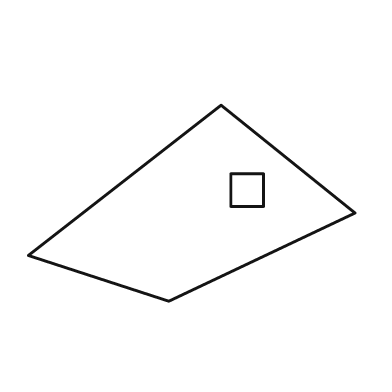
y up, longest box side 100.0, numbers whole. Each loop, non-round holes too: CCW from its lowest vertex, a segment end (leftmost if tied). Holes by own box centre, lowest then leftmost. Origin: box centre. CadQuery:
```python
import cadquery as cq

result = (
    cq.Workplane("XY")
    .moveTo(-7.0, -30.0)
    .lineTo(50.0, -3.0)
    .lineTo(9.0, 30.0)
    .lineTo(-50.0, -16.0)
    .close()
    .moveTo(12.0, -1.0)
    .lineTo(22.0, -1.0)
    .lineTo(22.0, 9.0)
    .lineTo(12.0, 9.0)
    .close()
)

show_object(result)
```